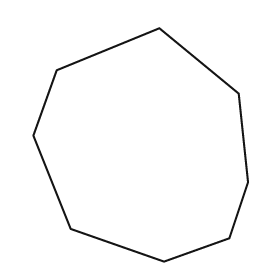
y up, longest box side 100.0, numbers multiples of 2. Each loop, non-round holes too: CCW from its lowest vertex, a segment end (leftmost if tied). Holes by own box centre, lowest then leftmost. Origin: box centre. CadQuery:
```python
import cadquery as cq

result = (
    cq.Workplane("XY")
    .moveTo(10.0, -50.0)
    .lineTo(38.0, -40.0)
    .lineTo(46.0, -16.0)
    .lineTo(42.0, 22.0)
    .lineTo(8.0, 50.0)
    .lineTo(-36.0, 32.0)
    .lineTo(-46.0, 4.0)
    .lineTo(-30.0, -36.0)
    .close()
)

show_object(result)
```